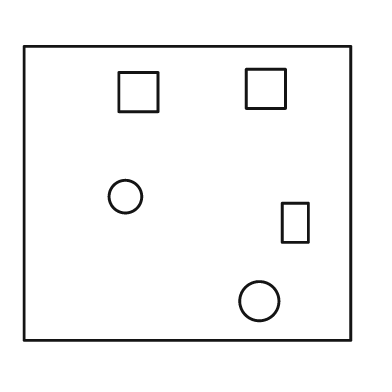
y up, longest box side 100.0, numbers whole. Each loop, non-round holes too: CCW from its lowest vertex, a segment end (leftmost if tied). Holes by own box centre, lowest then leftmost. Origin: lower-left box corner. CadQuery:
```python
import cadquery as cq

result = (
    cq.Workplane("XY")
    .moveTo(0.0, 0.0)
    .lineTo(100.0, 0.0)
    .lineTo(100.0, 90.0)
    .lineTo(0.0, 90.0)
    .close()
    .moveTo(72.0, 12.0)
    .circle(6.0)
    .moveTo(79.0, 30.0)
    .lineTo(87.0, 30.0)
    .lineTo(87.0, 42.0)
    .lineTo(79.0, 42.0)
    .close()
    .moveTo(31.0, 44.0)
    .circle(5.0)
    .moveTo(29.0, 70.0)
    .lineTo(41.0, 70.0)
    .lineTo(41.0, 82.0)
    .lineTo(29.0, 82.0)
    .close()
    .moveTo(68.0, 71.0)
    .lineTo(80.0, 71.0)
    .lineTo(80.0, 83.0)
    .lineTo(68.0, 83.0)
    .close()
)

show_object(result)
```